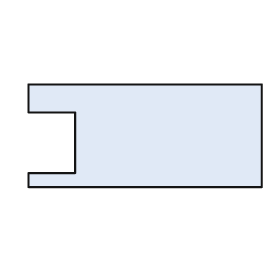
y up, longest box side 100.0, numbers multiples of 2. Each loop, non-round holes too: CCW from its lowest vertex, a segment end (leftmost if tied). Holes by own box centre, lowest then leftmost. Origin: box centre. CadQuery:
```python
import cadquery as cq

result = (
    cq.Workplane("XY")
    .moveTo(-50.0, -22.0)
    .lineTo(50.0, -22.0)
    .lineTo(50.0, 22.0)
    .lineTo(-50.0, 22.0)
    .lineTo(-50.0, 10.0)
    .lineTo(-30.0, 10.0)
    .lineTo(-30.0, -16.0)
    .lineTo(-50.0, -16.0)
    .close()
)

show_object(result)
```